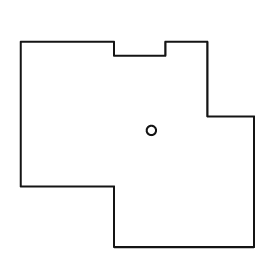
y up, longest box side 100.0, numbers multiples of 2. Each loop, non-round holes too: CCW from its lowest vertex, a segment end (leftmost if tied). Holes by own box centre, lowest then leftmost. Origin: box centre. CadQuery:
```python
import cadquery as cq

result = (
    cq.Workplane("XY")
    .moveTo(-10.0, -44.0)
    .lineTo(50.0, -44.0)
    .lineTo(50.0, 12.0)
    .lineTo(30.0, 12.0)
    .lineTo(30.0, 44.0)
    .lineTo(12.0, 44.0)
    .lineTo(12.0, 38.0)
    .lineTo(-10.0, 38.0)
    .lineTo(-10.0, 44.0)
    .lineTo(-50.0, 44.0)
    .lineTo(-50.0, -18.0)
    .lineTo(-10.0, -18.0)
    .close()
    .moveTo(6.0, 6.0)
    .circle(2.0)
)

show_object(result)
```